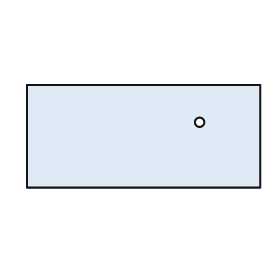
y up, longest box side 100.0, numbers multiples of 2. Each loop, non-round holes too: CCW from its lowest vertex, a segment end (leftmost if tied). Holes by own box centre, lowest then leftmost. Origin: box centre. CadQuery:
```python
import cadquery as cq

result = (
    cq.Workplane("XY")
    .moveTo(-50.0, -22.0)
    .lineTo(50.0, -22.0)
    .lineTo(50.0, 22.0)
    .lineTo(-50.0, 22.0)
    .close()
    .moveTo(24.0, 6.0)
    .circle(2.0)
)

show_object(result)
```